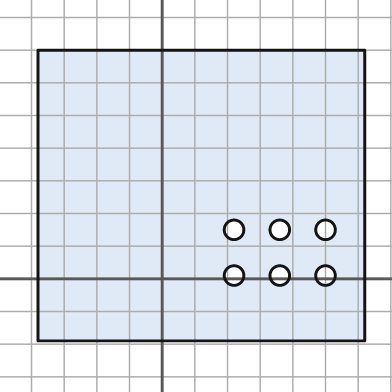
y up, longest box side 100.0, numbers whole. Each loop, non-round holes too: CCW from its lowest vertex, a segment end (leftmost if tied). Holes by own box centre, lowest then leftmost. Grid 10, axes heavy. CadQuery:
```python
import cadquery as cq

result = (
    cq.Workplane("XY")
    .moveTo(-38.0, -19.0)
    .lineTo(62.0, -19.0)
    .lineTo(62.0, 70.0)
    .lineTo(-38.0, 70.0)
    .close()
    .moveTo(22.0, 1.0)
    .circle(3.0)
    .moveTo(36.0, 1.0)
    .circle(3.0)
    .moveTo(50.0, 1.0)
    .circle(3.0)
    .moveTo(22.0, 15.0)
    .circle(3.0)
    .moveTo(36.0, 15.0)
    .circle(3.0)
    .moveTo(50.0, 15.0)
    .circle(3.0)
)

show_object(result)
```